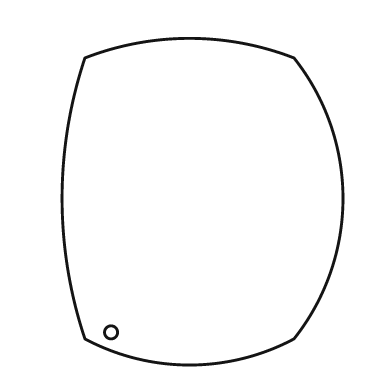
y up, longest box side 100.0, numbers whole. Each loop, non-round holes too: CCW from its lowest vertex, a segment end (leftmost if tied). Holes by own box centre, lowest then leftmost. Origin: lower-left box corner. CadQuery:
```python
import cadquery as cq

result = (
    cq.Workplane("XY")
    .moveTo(7.0, 8.0)
    .threePointArc((39.0, 0.0), (71.0, 8.0))
    .threePointArc((86.0, 51.0), (71.0, 94.0))
    .threePointArc((39.0, 100.0), (7.0, 94.0))
    .threePointArc((0.0, 51.0), (7.0, 8.0))
    .close()
    .moveTo(15.0, 10.0)
    .circle(2.0)
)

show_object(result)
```